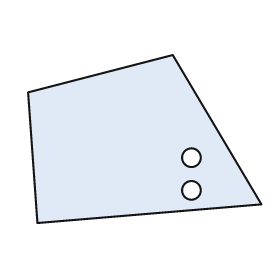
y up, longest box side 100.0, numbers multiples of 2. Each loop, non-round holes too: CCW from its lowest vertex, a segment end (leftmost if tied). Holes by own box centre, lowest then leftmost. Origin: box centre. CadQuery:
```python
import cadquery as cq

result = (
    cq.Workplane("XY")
    .moveTo(-46.0, -36.0)
    .lineTo(50.0, -28.0)
    .lineTo(12.0, 36.0)
    .lineTo(-50.0, 20.0)
    .close()
    .moveTo(20.0, -22.0)
    .circle(4.0)
    .moveTo(20.0, -8.0)
    .circle(4.0)
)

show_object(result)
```